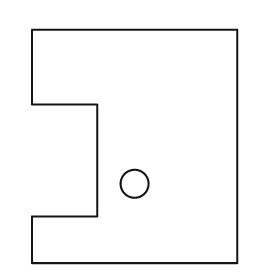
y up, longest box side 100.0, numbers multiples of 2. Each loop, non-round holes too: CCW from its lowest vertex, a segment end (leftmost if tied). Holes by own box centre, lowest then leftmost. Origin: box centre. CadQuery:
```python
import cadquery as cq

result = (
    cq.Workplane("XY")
    .moveTo(-44.0, -50.0)
    .lineTo(44.0, -50.0)
    .lineTo(44.0, 50.0)
    .lineTo(-44.0, 50.0)
    .lineTo(-44.0, 18.0)
    .lineTo(-16.0, 18.0)
    .lineTo(-16.0, -30.0)
    .lineTo(-44.0, -30.0)
    .close()
    .moveTo(0.0, -16.0)
    .circle(6.0)
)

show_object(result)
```